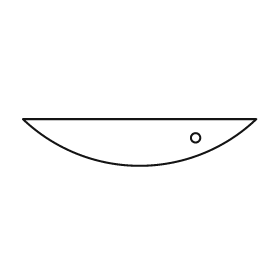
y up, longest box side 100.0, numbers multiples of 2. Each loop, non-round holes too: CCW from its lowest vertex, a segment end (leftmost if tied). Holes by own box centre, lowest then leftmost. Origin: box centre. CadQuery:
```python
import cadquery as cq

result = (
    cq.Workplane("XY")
    .moveTo(-50.0, 10.0)
    .threePointArc((0.0, -10.0), (50.0, 10.0))
    .close()
    .moveTo(24.0, 2.0)
    .circle(2.0)
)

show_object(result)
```